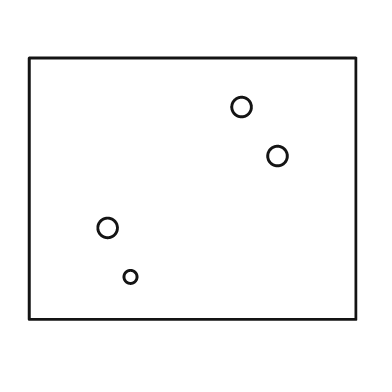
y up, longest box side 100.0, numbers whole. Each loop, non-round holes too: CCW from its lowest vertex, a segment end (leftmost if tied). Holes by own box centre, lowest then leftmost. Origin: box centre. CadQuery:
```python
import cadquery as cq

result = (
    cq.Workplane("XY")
    .moveTo(-50.0, -40.0)
    .lineTo(50.0, -40.0)
    .lineTo(50.0, 40.0)
    .lineTo(-50.0, 40.0)
    .close()
    .moveTo(-19.0, -27.0)
    .circle(2.0)
    .moveTo(-26.0, -12.0)
    .circle(3.0)
    .moveTo(26.0, 10.0)
    .circle(3.0)
    .moveTo(15.0, 25.0)
    .circle(3.0)
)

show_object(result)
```